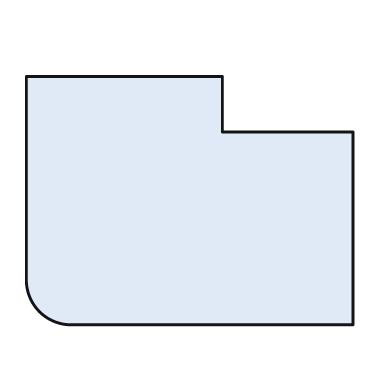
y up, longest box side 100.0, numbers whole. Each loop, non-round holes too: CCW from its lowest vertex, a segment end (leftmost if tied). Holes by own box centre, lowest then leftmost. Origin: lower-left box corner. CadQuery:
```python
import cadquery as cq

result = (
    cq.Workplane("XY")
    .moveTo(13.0, 0.0)
    .lineTo(100.0, 0.0)
    .lineTo(100.0, 59.0)
    .lineTo(60.0, 59.0)
    .lineTo(60.0, 76.0)
    .lineTo(0.0, 76.0)
    .lineTo(0.0, 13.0)
    .threePointArc((4.0, 4.0), (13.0, 0.0))
    .close()
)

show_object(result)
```